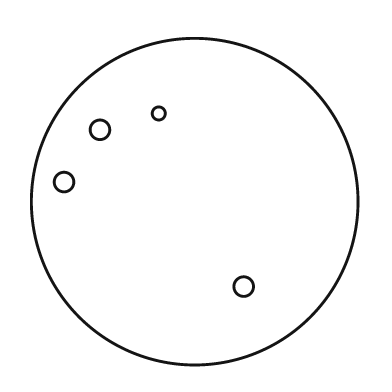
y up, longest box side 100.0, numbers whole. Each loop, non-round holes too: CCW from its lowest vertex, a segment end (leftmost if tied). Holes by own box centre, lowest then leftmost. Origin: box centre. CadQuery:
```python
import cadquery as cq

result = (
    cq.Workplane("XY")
    .moveTo(0.0, 0.0)
    .circle(50.0)
    .moveTo(15.0, -26.0)
    .circle(3.0)
    .moveTo(-40.0, 6.0)
    .circle(3.0)
    .moveTo(-29.0, 22.0)
    .circle(3.0)
    .moveTo(-11.0, 27.0)
    .circle(2.0)
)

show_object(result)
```